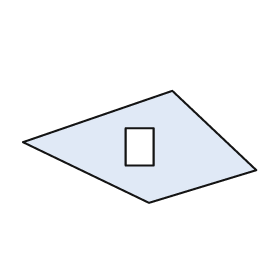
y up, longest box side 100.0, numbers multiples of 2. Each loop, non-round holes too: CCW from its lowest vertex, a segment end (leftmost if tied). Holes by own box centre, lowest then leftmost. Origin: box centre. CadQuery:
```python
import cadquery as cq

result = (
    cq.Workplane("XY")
    .moveTo(4.0, -24.0)
    .lineTo(50.0, -10.0)
    .lineTo(14.0, 24.0)
    .lineTo(-50.0, 2.0)
    .close()
    .moveTo(-6.0, -8.0)
    .lineTo(6.0, -8.0)
    .lineTo(6.0, 8.0)
    .lineTo(-6.0, 8.0)
    .close()
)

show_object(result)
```